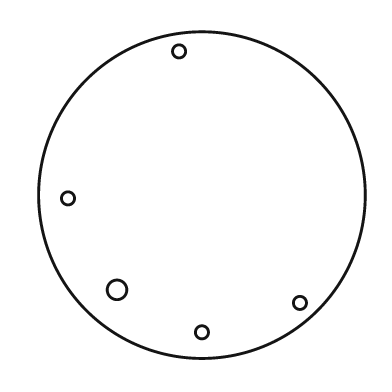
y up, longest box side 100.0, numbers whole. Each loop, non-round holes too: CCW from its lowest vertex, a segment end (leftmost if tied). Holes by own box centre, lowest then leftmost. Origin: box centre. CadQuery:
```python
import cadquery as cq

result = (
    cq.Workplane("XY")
    .moveTo(0.0, 0.0)
    .circle(50.0)
    .moveTo(0.0, -42.0)
    .circle(2.0)
    .moveTo(30.0, -33.0)
    .circle(2.0)
    .moveTo(-26.0, -29.0)
    .circle(3.0)
    .moveTo(-41.0, -1.0)
    .circle(2.0)
    .moveTo(-7.0, 44.0)
    .circle(2.0)
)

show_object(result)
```